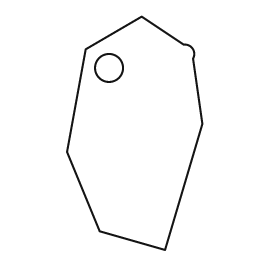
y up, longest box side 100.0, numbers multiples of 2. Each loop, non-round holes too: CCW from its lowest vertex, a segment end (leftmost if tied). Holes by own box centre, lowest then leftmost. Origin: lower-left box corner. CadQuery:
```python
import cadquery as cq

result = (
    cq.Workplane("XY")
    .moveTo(42.0, 0.0)
    .lineTo(58.0, 54.0)
    .lineTo(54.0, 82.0)
    .threePointArc((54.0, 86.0), (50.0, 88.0))
    .lineTo(32.0, 100.0)
    .lineTo(8.0, 86.0)
    .lineTo(0.0, 42.0)
    .lineTo(14.0, 8.0)
    .close()
    .moveTo(18.0, 78.0)
    .circle(6.0)
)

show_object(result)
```